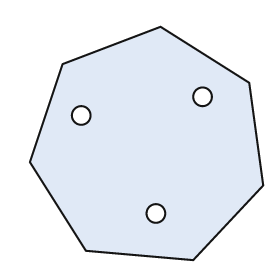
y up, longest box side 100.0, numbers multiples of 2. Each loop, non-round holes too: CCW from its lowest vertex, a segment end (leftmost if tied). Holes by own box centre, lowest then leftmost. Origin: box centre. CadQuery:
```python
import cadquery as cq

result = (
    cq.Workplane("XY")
    .moveTo(20.0, -50.0)
    .lineTo(50.0, -18.0)
    .lineTo(44.0, 26.0)
    .lineTo(6.0, 50.0)
    .lineTo(-36.0, 34.0)
    .lineTo(-50.0, -8.0)
    .lineTo(-26.0, -46.0)
    .close()
    .moveTo(4.0, -30.0)
    .circle(4.0)
    .moveTo(-28.0, 12.0)
    .circle(4.0)
    .moveTo(24.0, 20.0)
    .circle(4.0)
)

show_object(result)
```